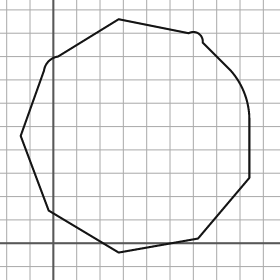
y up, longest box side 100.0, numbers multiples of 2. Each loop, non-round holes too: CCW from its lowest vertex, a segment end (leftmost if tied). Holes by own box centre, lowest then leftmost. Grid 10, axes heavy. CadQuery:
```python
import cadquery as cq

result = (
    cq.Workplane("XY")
    .moveTo(28.0, -4.0)
    .lineTo(62.0, 2.0)
    .lineTo(84.0, 28.0)
    .lineTo(84.0, 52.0)
    .threePointArc((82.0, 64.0), (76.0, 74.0))
    .lineTo(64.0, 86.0)
    .threePointArc((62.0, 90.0), (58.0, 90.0))
    .lineTo(28.0, 96.0)
    .lineTo(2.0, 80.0)
    .threePointArc((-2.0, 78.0), (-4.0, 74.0))
    .lineTo(-14.0, 46.0)
    .lineTo(-2.0, 14.0)
    .close()
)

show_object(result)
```